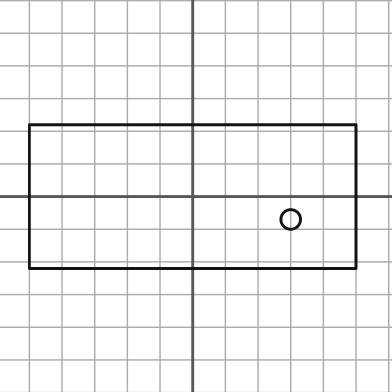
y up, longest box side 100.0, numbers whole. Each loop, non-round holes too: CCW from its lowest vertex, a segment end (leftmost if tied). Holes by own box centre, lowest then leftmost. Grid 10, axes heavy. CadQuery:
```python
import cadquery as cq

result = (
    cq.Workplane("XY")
    .moveTo(-50.0, -22.0)
    .lineTo(50.0, -22.0)
    .lineTo(50.0, 22.0)
    .lineTo(-50.0, 22.0)
    .close()
    .moveTo(30.0, -7.0)
    .circle(3.0)
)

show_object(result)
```